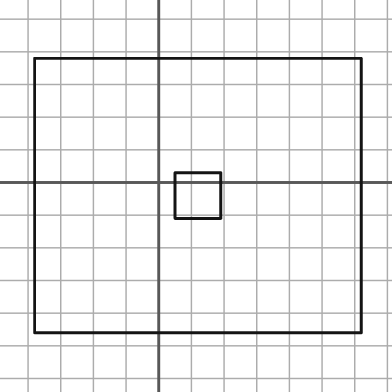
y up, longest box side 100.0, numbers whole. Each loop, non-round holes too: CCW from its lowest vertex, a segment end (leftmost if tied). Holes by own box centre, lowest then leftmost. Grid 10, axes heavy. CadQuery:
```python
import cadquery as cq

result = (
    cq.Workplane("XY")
    .moveTo(-38.0, -46.0)
    .lineTo(62.0, -46.0)
    .lineTo(62.0, 38.0)
    .lineTo(-38.0, 38.0)
    .close()
    .moveTo(5.0, -11.0)
    .lineTo(19.0, -11.0)
    .lineTo(19.0, 3.0)
    .lineTo(5.0, 3.0)
    .close()
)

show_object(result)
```